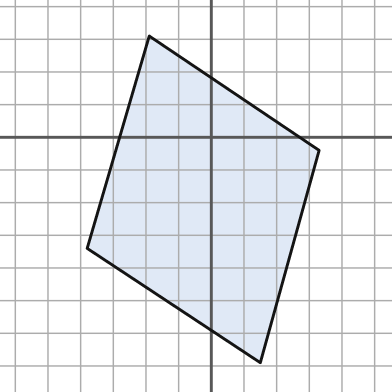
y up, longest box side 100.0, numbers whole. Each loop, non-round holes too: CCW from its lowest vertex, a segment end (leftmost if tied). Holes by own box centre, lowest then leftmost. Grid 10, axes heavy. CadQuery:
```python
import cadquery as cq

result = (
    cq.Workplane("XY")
    .moveTo(15.0, -69.0)
    .lineTo(33.0, -4.0)
    .lineTo(-19.0, 31.0)
    .lineTo(-38.0, -34.0)
    .close()
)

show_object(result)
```